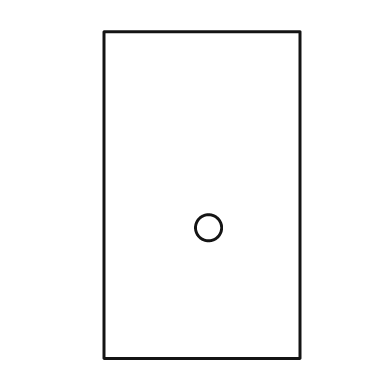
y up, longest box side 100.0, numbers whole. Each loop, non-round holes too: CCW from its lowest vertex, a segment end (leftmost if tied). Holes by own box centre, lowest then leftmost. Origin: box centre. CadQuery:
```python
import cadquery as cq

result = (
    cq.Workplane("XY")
    .moveTo(-30.0, -50.0)
    .lineTo(30.0, -50.0)
    .lineTo(30.0, 50.0)
    .lineTo(-30.0, 50.0)
    .close()
    .moveTo(2.0, -10.0)
    .circle(4.0)
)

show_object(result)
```